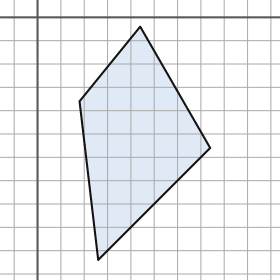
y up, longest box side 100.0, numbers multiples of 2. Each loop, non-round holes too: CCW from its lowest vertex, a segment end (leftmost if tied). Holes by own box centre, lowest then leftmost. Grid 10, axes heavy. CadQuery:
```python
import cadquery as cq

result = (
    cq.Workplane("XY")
    .moveTo(26.0, -104.0)
    .lineTo(74.0, -56.0)
    .lineTo(44.0, -4.0)
    .lineTo(18.0, -36.0)
    .close()
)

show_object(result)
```